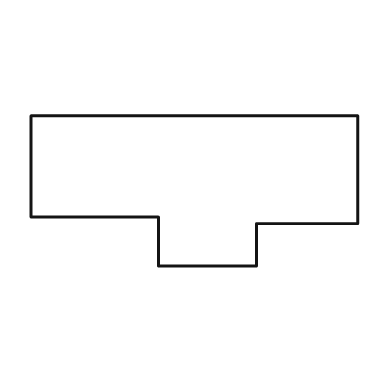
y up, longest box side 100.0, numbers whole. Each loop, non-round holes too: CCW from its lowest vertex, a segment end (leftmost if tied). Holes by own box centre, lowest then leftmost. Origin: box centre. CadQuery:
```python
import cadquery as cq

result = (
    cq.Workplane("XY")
    .moveTo(-11.0, -23.0)
    .lineTo(19.0, -23.0)
    .lineTo(19.0, -10.0)
    .lineTo(50.0, -10.0)
    .lineTo(50.0, 23.0)
    .lineTo(-50.0, 23.0)
    .lineTo(-50.0, -8.0)
    .lineTo(-11.0, -8.0)
    .close()
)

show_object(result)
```